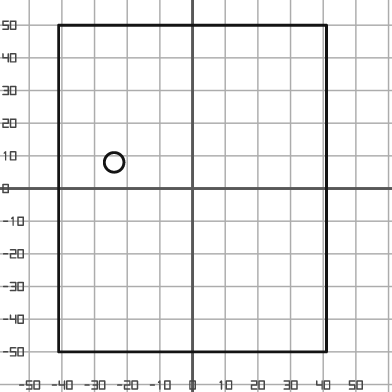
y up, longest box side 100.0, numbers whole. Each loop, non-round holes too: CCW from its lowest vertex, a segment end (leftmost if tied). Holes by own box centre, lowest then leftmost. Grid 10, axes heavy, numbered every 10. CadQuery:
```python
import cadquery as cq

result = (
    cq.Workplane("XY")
    .moveTo(-41.0, -50.0)
    .lineTo(41.0, -50.0)
    .lineTo(41.0, 50.0)
    .lineTo(-41.0, 50.0)
    .close()
    .moveTo(-24.0, 8.0)
    .circle(3.0)
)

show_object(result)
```